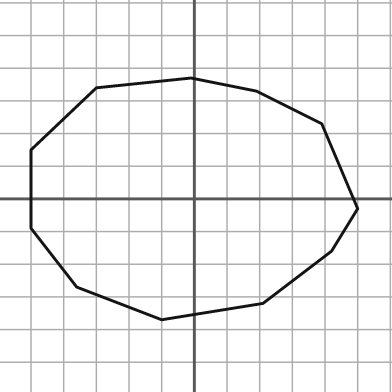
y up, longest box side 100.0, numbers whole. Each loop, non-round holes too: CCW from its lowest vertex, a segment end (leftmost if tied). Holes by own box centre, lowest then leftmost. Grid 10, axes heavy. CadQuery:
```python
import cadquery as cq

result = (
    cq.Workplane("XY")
    .moveTo(-10.0, -37.0)
    .lineTo(21.0, -32.0)
    .lineTo(42.0, -16.0)
    .lineTo(50.0, -3.0)
    .lineTo(39.0, 23.0)
    .lineTo(19.0, 33.0)
    .lineTo(-1.0, 37.0)
    .lineTo(-30.0, 34.0)
    .lineTo(-50.0, 15.0)
    .lineTo(-50.0, -9.0)
    .lineTo(-36.0, -27.0)
    .close()
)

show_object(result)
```